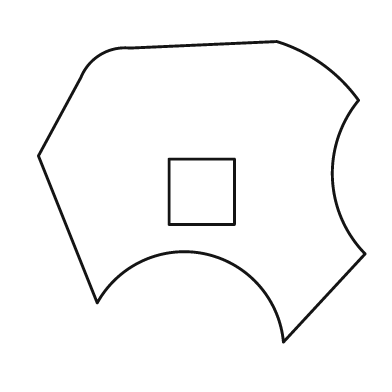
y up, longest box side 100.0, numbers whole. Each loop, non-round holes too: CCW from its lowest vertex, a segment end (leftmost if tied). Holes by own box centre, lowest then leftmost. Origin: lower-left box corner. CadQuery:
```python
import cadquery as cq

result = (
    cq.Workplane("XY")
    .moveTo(75.0, 0.0)
    .lineTo(100.0, 27.0)
    .threePointArc((90.0, 50.0), (98.0, 74.0))
    .threePointArc((87.0, 85.0), (73.0, 92.0))
    .lineTo(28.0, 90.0)
    .threePointArc((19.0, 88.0), (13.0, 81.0))
    .lineTo(0.0, 57.0)
    .lineTo(18.0, 12.0)
    .threePointArc((51.0, 27.0), (75.0, 0.0))
    .close()
    .moveTo(40.0, 36.0)
    .lineTo(60.0, 36.0)
    .lineTo(60.0, 56.0)
    .lineTo(40.0, 56.0)
    .close()
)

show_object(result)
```